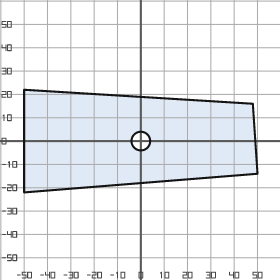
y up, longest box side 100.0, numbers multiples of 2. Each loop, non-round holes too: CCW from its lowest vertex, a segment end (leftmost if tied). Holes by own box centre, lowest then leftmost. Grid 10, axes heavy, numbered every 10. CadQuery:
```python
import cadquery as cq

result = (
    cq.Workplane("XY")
    .moveTo(-50.0, -22.0)
    .lineTo(50.0, -14.0)
    .lineTo(48.0, 16.0)
    .lineTo(-50.0, 22.0)
    .close()
    .moveTo(0.0, 0.0)
    .circle(4.0)
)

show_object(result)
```